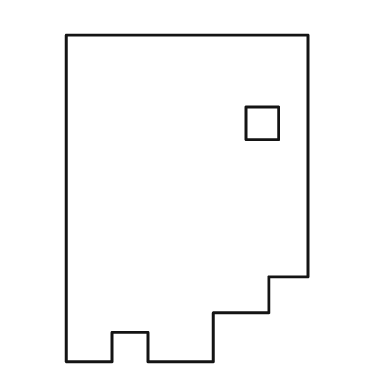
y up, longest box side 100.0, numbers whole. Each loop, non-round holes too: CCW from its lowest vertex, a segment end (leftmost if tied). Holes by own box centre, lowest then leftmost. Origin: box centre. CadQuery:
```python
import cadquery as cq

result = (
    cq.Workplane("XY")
    .moveTo(-37.0, -50.0)
    .lineTo(-23.0, -50.0)
    .lineTo(-23.0, -41.0)
    .lineTo(-12.0, -41.0)
    .lineTo(-12.0, -50.0)
    .lineTo(8.0, -50.0)
    .lineTo(8.0, -35.0)
    .lineTo(25.0, -35.0)
    .lineTo(25.0, -24.0)
    .lineTo(37.0, -24.0)
    .lineTo(37.0, 50.0)
    .lineTo(-37.0, 50.0)
    .close()
    .moveTo(18.0, 18.0)
    .lineTo(28.0, 18.0)
    .lineTo(28.0, 28.0)
    .lineTo(18.0, 28.0)
    .close()
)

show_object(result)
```